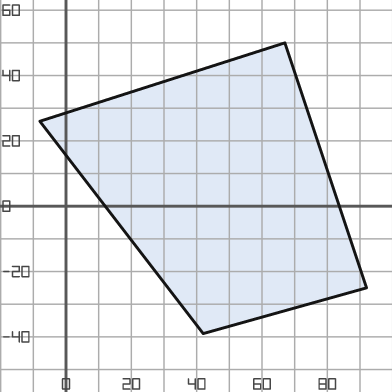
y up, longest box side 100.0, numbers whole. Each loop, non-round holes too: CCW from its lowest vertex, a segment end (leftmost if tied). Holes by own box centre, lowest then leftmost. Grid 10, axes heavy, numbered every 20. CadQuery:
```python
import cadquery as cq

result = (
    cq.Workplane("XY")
    .moveTo(42.0, -39.0)
    .lineTo(92.0, -25.0)
    .lineTo(67.0, 50.0)
    .lineTo(-8.0, 26.0)
    .close()
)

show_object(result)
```